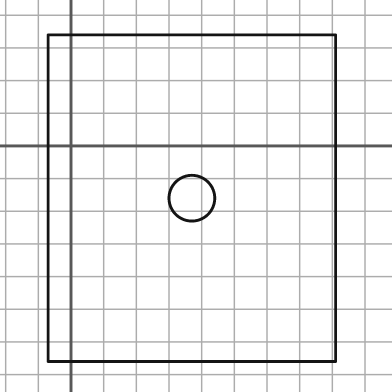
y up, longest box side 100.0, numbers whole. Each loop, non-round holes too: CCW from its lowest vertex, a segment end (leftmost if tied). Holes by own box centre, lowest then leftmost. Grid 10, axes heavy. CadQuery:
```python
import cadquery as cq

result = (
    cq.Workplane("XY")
    .moveTo(-7.0, -66.0)
    .lineTo(81.0, -66.0)
    .lineTo(81.0, 34.0)
    .lineTo(-7.0, 34.0)
    .close()
    .moveTo(37.0, -16.0)
    .circle(7.0)
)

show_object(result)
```